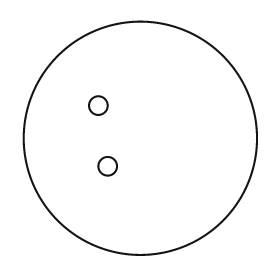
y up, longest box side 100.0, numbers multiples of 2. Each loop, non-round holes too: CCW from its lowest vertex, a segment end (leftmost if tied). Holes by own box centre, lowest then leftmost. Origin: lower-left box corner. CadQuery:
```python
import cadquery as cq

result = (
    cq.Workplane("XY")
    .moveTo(50.0, 50.0)
    .circle(50.0)
    .moveTo(36.0, 38.0)
    .circle(4.0)
    .moveTo(32.0, 64.0)
    .circle(4.0)
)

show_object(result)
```